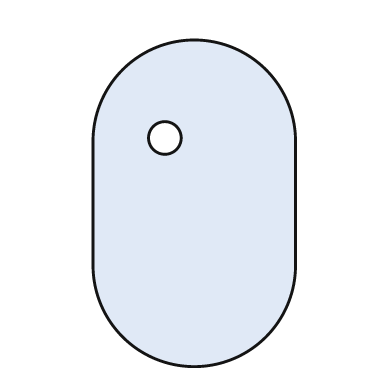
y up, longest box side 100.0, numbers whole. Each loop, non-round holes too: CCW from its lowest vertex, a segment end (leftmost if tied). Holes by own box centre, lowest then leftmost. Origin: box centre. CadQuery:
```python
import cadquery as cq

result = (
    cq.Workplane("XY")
    .moveTo(-31.0, -19.0)
    .threePointArc((0.0, -50.0), (31.0, -19.0))
    .lineTo(31.0, 19.0)
    .threePointArc((0.0, 50.0), (-31.0, 19.0))
    .close()
    .moveTo(-9.0, 20.0)
    .circle(5.0)
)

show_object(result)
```